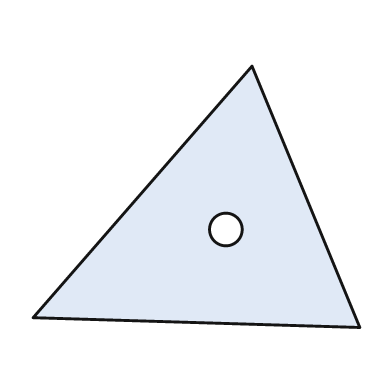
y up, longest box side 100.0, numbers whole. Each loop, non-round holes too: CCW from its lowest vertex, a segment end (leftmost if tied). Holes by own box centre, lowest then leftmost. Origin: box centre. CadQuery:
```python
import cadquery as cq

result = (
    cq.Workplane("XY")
    .moveTo(50.0, -40.0)
    .lineTo(17.0, 40.0)
    .lineTo(-50.0, -37.0)
    .close()
    .moveTo(9.0, -10.0)
    .circle(5.0)
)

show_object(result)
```